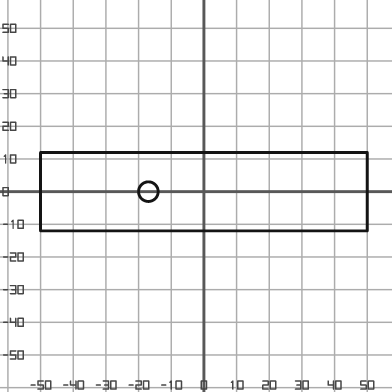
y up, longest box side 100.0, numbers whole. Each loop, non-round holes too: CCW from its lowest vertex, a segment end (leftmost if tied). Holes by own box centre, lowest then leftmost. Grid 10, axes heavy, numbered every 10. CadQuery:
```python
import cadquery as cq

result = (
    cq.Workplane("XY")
    .moveTo(-50.0, -12.0)
    .lineTo(50.0, -12.0)
    .lineTo(50.0, 12.0)
    .lineTo(-50.0, 12.0)
    .close()
    .moveTo(-17.0, 0.0)
    .circle(3.0)
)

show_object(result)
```